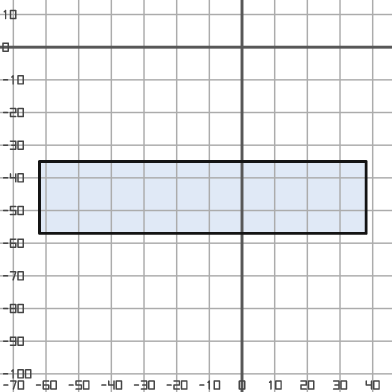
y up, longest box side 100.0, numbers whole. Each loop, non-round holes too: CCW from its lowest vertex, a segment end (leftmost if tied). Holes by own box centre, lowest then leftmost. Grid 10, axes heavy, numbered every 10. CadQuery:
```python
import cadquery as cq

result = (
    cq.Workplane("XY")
    .moveTo(-62.0, -57.0)
    .lineTo(38.0, -57.0)
    .lineTo(38.0, -35.0)
    .lineTo(-62.0, -35.0)
    .close()
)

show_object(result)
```